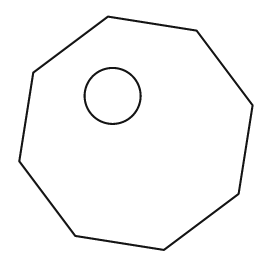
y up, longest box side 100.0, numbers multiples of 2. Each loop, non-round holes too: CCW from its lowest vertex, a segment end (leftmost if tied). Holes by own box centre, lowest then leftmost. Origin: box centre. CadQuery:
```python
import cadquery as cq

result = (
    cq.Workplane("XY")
    .moveTo(12.0, -50.0)
    .lineTo(44.0, -26.0)
    .lineTo(50.0, 12.0)
    .lineTo(26.0, 44.0)
    .lineTo(-12.0, 50.0)
    .lineTo(-44.0, 26.0)
    .lineTo(-50.0, -12.0)
    .lineTo(-26.0, -44.0)
    .close()
    .moveTo(-10.0, 16.0)
    .circle(12.0)
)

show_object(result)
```